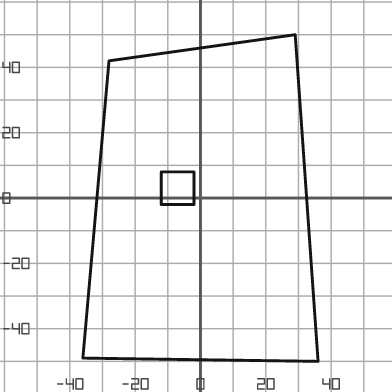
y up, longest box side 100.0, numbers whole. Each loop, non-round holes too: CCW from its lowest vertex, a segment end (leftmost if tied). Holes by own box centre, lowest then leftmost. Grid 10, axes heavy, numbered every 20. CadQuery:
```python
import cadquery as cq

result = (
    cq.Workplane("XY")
    .moveTo(36.0, -50.0)
    .lineTo(29.0, 50.0)
    .lineTo(-28.0, 42.0)
    .lineTo(-36.0, -49.0)
    .close()
    .moveTo(-12.0, -2.0)
    .lineTo(-2.0, -2.0)
    .lineTo(-2.0, 8.0)
    .lineTo(-12.0, 8.0)
    .close()
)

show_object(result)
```